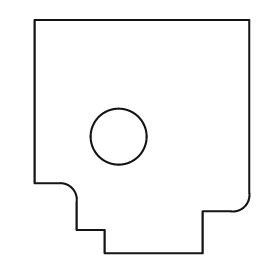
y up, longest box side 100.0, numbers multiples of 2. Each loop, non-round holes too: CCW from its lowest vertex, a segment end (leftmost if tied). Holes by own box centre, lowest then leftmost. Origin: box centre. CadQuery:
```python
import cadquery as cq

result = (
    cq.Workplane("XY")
    .moveTo(-16.0, -50.0)
    .lineTo(26.0, -50.0)
    .lineTo(26.0, -32.0)
    .lineTo(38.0, -32.0)
    .threePointArc((44.0, -30.0), (46.0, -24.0))
    .lineTo(46.0, 50.0)
    .lineTo(-46.0, 50.0)
    .lineTo(-46.0, -20.0)
    .lineTo(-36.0, -20.0)
    .threePointArc((-30.0, -22.0), (-28.0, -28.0))
    .lineTo(-28.0, -40.0)
    .lineTo(-16.0, -40.0)
    .close()
    .moveTo(-10.0, 0.0)
    .circle(12.0)
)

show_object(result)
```